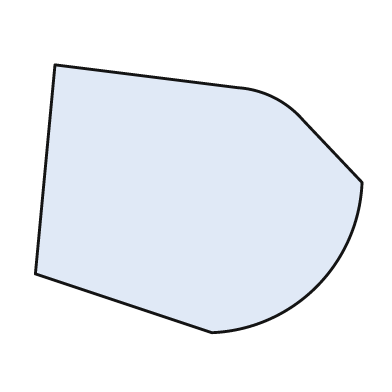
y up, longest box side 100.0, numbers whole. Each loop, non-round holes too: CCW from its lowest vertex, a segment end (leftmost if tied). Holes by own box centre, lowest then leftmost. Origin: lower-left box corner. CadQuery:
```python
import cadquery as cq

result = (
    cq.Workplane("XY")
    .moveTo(54.0, 0.0)
    .threePointArc((86.0, 14.0), (100.0, 46.0))
    .lineTo(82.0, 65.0)
    .threePointArc((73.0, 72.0), (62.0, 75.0))
    .lineTo(6.0, 82.0)
    .lineTo(0.0, 18.0)
    .close()
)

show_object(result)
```